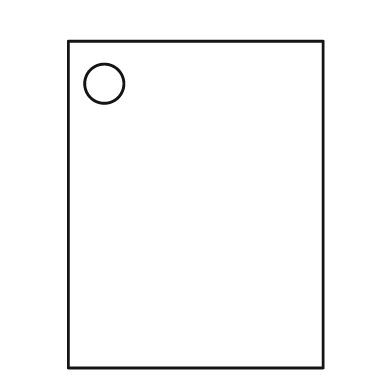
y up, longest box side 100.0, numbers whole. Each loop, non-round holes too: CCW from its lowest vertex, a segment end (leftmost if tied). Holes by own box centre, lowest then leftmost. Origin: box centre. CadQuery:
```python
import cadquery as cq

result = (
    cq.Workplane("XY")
    .moveTo(-39.0, -50.0)
    .lineTo(39.0, -50.0)
    .lineTo(39.0, 50.0)
    .lineTo(-39.0, 50.0)
    .close()
    .moveTo(-28.0, 37.0)
    .circle(6.0)
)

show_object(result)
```